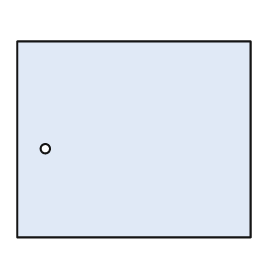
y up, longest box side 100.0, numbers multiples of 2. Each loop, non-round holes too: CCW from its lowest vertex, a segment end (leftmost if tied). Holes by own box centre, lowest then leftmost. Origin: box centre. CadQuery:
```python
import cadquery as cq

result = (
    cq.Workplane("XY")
    .moveTo(-50.0, -42.0)
    .lineTo(50.0, -42.0)
    .lineTo(50.0, 42.0)
    .lineTo(-50.0, 42.0)
    .close()
    .moveTo(-38.0, -4.0)
    .circle(2.0)
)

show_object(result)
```